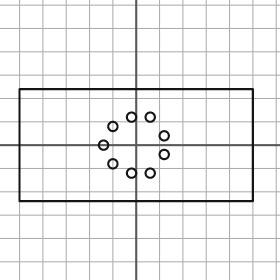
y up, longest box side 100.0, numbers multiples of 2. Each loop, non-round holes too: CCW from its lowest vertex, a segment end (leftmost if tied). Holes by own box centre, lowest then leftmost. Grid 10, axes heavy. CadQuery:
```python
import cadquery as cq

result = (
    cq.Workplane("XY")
    .moveTo(-50.0, -24.0)
    .lineTo(50.0, -24.0)
    .lineTo(50.0, 24.0)
    .lineTo(-50.0, 24.0)
    .close()
    .moveTo(-2.0, -12.0)
    .circle(2.0)
    .moveTo(6.0, -12.0)
    .circle(2.0)
    .moveTo(-10.0, -8.0)
    .circle(2.0)
    .moveTo(12.0, -4.0)
    .circle(2.0)
    .moveTo(-14.0, 0.0)
    .circle(2.0)
    .moveTo(12.0, 4.0)
    .circle(2.0)
    .moveTo(-10.0, 8.0)
    .circle(2.0)
    .moveTo(-2.0, 12.0)
    .circle(2.0)
    .moveTo(6.0, 12.0)
    .circle(2.0)
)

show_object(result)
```